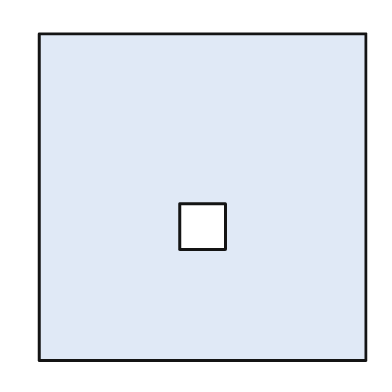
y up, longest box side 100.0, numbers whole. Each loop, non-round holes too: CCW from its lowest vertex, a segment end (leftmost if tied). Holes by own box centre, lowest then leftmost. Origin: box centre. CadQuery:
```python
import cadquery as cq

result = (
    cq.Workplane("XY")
    .moveTo(-50.0, -50.0)
    .lineTo(50.0, -50.0)
    .lineTo(50.0, 50.0)
    .lineTo(-50.0, 50.0)
    .close()
    .moveTo(-7.0, -16.0)
    .lineTo(7.0, -16.0)
    .lineTo(7.0, -2.0)
    .lineTo(-7.0, -2.0)
    .close()
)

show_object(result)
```